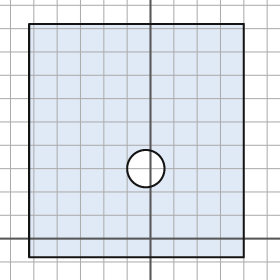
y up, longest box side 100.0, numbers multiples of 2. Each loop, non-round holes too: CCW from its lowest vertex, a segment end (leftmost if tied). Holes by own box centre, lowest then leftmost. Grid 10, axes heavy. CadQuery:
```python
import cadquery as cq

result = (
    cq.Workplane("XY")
    .moveTo(-52.0, -8.0)
    .lineTo(40.0, -8.0)
    .lineTo(40.0, 92.0)
    .lineTo(-52.0, 92.0)
    .close()
    .moveTo(-2.0, 30.0)
    .circle(8.0)
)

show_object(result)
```